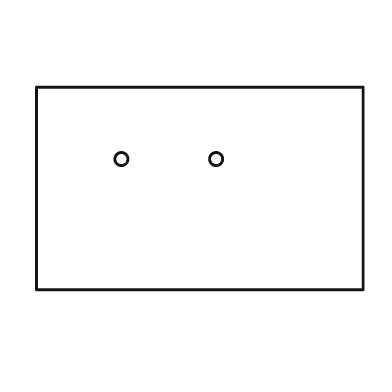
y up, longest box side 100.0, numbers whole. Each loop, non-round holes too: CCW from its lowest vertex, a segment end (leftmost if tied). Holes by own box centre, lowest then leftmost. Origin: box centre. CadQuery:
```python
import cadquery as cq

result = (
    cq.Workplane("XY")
    .moveTo(-50.0, -31.0)
    .lineTo(50.0, -31.0)
    .lineTo(50.0, 31.0)
    .lineTo(-50.0, 31.0)
    .close()
    .moveTo(-24.0, 9.0)
    .circle(2.0)
    .moveTo(5.0, 9.0)
    .circle(2.0)
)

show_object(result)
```